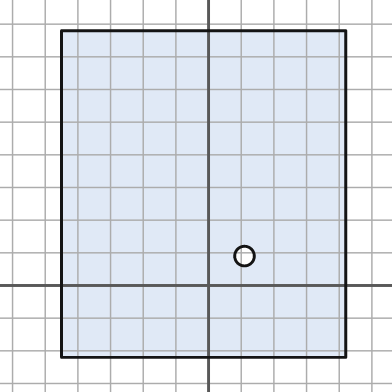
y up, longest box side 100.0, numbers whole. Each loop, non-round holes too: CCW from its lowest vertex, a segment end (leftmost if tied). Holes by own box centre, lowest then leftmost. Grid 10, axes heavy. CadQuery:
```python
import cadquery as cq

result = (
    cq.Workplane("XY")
    .moveTo(-45.0, -22.0)
    .lineTo(42.0, -22.0)
    .lineTo(42.0, 78.0)
    .lineTo(-45.0, 78.0)
    .close()
    .moveTo(11.0, 9.0)
    .circle(3.0)
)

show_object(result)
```